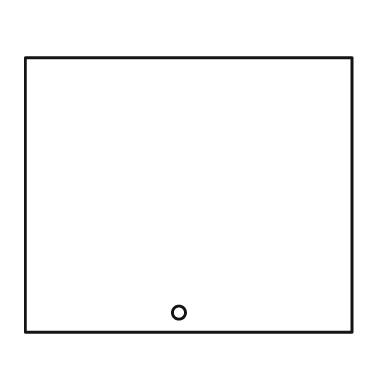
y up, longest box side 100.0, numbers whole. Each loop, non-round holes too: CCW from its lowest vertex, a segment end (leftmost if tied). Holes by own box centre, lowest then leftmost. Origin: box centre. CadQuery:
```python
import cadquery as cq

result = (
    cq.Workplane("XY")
    .moveTo(-50.0, -42.0)
    .lineTo(50.0, -42.0)
    .lineTo(50.0, 42.0)
    .lineTo(-50.0, 42.0)
    .close()
    .moveTo(-3.0, -36.0)
    .circle(2.0)
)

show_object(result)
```